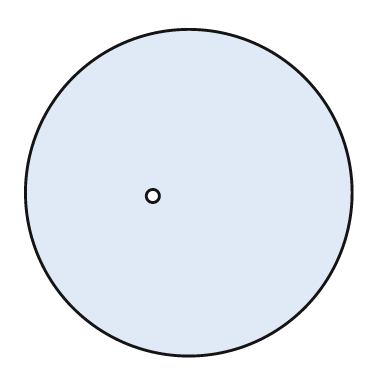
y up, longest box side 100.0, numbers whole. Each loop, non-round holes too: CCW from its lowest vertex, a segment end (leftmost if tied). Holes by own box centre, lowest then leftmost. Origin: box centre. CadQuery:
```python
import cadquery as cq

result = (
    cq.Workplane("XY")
    .moveTo(0.0, 0.0)
    .circle(50.0)
    .moveTo(-11.0, -1.0)
    .circle(2.0)
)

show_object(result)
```